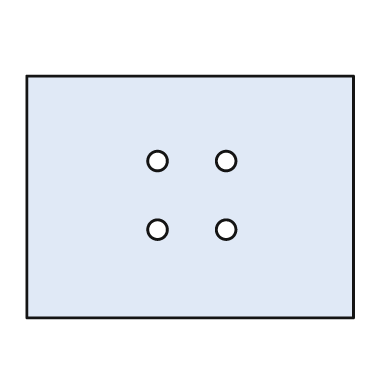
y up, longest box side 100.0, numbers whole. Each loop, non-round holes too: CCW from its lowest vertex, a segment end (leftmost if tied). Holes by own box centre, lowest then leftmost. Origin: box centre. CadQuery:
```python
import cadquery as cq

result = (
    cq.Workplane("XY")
    .moveTo(-50.0, -37.0)
    .lineTo(50.0, -37.0)
    .lineTo(50.0, 37.0)
    .lineTo(-50.0, 37.0)
    .close()
    .moveTo(-10.0, -10.0)
    .circle(3.0)
    .moveTo(11.0, -10.0)
    .circle(3.0)
    .moveTo(-10.0, 11.0)
    .circle(3.0)
    .moveTo(11.0, 11.0)
    .circle(3.0)
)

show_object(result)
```